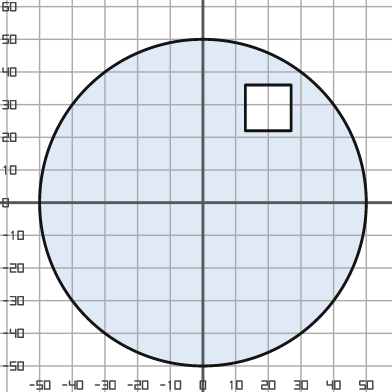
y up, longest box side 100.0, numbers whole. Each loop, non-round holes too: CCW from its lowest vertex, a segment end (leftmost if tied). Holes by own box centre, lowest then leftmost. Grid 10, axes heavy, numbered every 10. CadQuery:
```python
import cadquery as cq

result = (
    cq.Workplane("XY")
    .moveTo(0.0, 0.0)
    .circle(50.0)
    .moveTo(13.0, 22.0)
    .lineTo(27.0, 22.0)
    .lineTo(27.0, 36.0)
    .lineTo(13.0, 36.0)
    .close()
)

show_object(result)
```